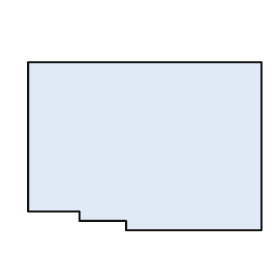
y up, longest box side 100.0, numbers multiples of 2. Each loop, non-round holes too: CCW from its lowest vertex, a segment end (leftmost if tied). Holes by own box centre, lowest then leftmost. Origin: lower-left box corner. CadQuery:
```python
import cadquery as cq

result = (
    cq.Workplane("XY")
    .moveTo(42.0, 0.0)
    .lineTo(100.0, 0.0)
    .lineTo(100.0, 72.0)
    .lineTo(0.0, 72.0)
    .lineTo(0.0, 8.0)
    .lineTo(22.0, 8.0)
    .lineTo(22.0, 4.0)
    .lineTo(42.0, 4.0)
    .close()
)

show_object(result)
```